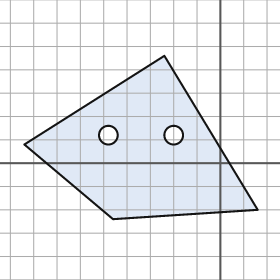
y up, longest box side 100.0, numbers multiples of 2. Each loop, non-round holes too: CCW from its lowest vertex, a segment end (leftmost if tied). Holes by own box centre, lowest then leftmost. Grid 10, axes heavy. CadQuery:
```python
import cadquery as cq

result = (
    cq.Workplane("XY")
    .moveTo(-46.0, -24.0)
    .lineTo(16.0, -20.0)
    .lineTo(-24.0, 46.0)
    .lineTo(-84.0, 8.0)
    .close()
    .moveTo(-48.0, 12.0)
    .circle(4.0)
    .moveTo(-20.0, 12.0)
    .circle(4.0)
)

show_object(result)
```